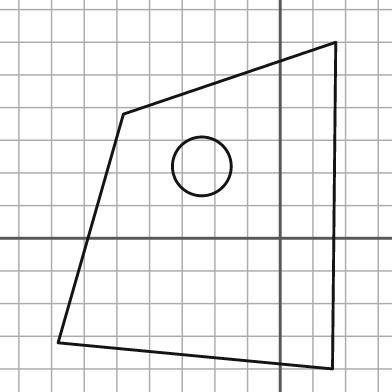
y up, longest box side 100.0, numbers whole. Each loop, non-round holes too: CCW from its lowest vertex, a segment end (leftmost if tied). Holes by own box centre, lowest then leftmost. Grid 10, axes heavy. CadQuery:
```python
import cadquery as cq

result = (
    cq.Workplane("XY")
    .moveTo(16.0, -40.0)
    .lineTo(17.0, 60.0)
    .lineTo(-48.0, 38.0)
    .lineTo(-68.0, -32.0)
    .close()
    .moveTo(-24.0, 22.0)
    .circle(9.0)
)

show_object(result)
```